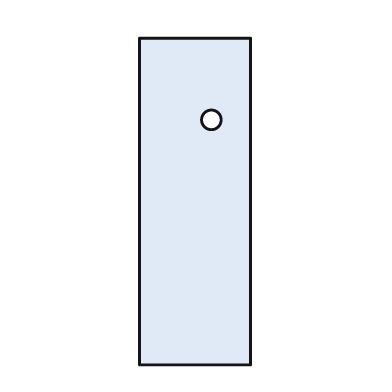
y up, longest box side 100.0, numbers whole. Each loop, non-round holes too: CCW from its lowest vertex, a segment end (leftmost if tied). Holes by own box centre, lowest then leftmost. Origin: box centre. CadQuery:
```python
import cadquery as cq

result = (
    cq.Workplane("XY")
    .moveTo(-17.0, -50.0)
    .lineTo(17.0, -50.0)
    .lineTo(17.0, 50.0)
    .lineTo(-17.0, 50.0)
    .close()
    .moveTo(5.0, 25.0)
    .circle(3.0)
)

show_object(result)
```